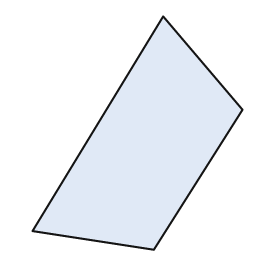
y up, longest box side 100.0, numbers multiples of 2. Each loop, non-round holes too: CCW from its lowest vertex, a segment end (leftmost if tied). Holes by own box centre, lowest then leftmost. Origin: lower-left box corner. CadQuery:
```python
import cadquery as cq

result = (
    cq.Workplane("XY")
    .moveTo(52.0, 0.0)
    .lineTo(90.0, 60.0)
    .lineTo(56.0, 100.0)
    .lineTo(0.0, 8.0)
    .close()
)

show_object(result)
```